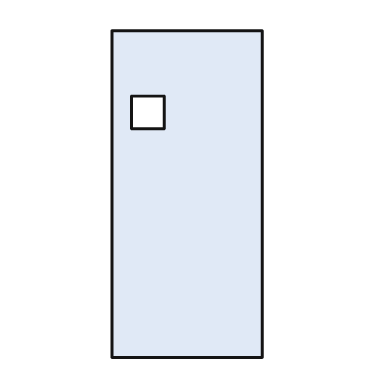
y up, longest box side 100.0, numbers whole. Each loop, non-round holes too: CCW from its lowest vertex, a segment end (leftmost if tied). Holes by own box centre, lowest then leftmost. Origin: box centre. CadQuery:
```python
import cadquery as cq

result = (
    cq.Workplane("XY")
    .moveTo(-23.0, -50.0)
    .lineTo(23.0, -50.0)
    .lineTo(23.0, 50.0)
    .lineTo(-23.0, 50.0)
    .close()
    .moveTo(-17.0, 20.0)
    .lineTo(-7.0, 20.0)
    .lineTo(-7.0, 30.0)
    .lineTo(-17.0, 30.0)
    .close()
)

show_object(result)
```